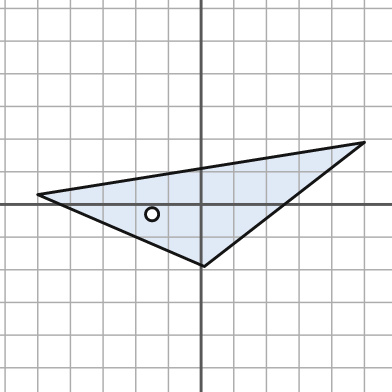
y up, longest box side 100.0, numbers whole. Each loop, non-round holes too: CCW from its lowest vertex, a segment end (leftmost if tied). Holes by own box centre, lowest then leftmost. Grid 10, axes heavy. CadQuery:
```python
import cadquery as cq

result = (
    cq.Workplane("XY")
    .moveTo(1.0, -19.0)
    .lineTo(50.0, 19.0)
    .lineTo(-50.0, 3.0)
    .close()
    .moveTo(-15.0, -3.0)
    .circle(2.0)
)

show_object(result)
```